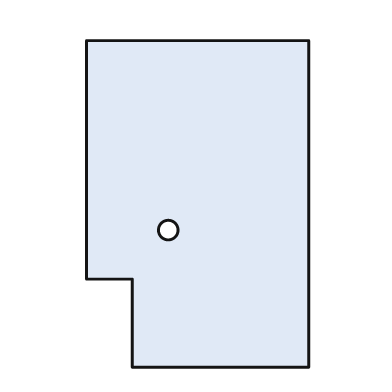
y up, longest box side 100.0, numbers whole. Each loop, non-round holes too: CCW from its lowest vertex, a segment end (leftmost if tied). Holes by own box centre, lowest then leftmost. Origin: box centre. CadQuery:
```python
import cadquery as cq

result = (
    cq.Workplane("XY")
    .moveTo(-20.0, -50.0)
    .lineTo(34.0, -50.0)
    .lineTo(34.0, 50.0)
    .lineTo(-34.0, 50.0)
    .lineTo(-34.0, -23.0)
    .lineTo(-20.0, -23.0)
    .close()
    .moveTo(-9.0, -8.0)
    .circle(3.0)
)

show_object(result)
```